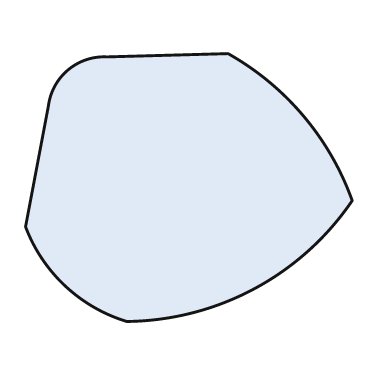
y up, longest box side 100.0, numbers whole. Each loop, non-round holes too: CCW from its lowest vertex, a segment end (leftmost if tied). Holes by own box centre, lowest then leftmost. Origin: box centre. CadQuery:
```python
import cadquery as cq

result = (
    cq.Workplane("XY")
    .moveTo(-19.0, -41.0)
    .threePointArc((20.0, -31.0), (50.0, -4.0))
    .threePointArc((35.0, 22.0), (12.0, 41.0))
    .lineTo(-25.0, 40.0)
    .threePointArc((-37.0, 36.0), (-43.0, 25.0))
    .lineTo(-50.0, -12.0)
    .threePointArc((-38.0, -30.0), (-19.0, -41.0))
    .close()
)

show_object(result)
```